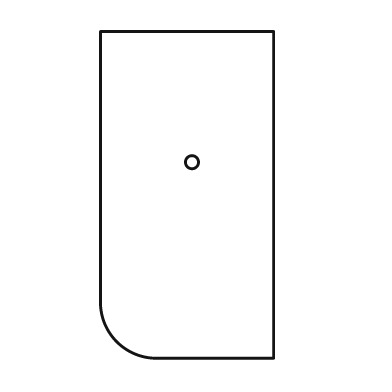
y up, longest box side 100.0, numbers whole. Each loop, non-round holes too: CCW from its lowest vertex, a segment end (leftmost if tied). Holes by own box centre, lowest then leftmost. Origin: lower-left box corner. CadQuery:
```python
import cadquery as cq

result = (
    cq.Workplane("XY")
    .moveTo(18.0, 0.0)
    .lineTo(53.0, 0.0)
    .lineTo(53.0, 100.0)
    .lineTo(0.0, 100.0)
    .lineTo(0.0, 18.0)
    .threePointArc((5.0, 5.0), (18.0, 0.0))
    .close()
    .moveTo(28.0, 60.0)
    .circle(2.0)
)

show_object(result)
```